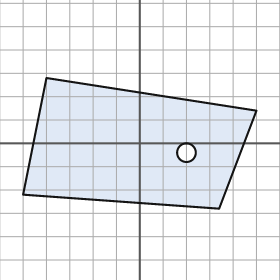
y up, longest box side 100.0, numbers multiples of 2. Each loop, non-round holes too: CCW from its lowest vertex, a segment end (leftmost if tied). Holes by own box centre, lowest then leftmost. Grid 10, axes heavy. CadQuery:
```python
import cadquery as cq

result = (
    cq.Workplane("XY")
    .moveTo(34.0, -28.0)
    .lineTo(50.0, 14.0)
    .lineTo(-40.0, 28.0)
    .lineTo(-50.0, -22.0)
    .close()
    .moveTo(20.0, -4.0)
    .circle(4.0)
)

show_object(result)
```